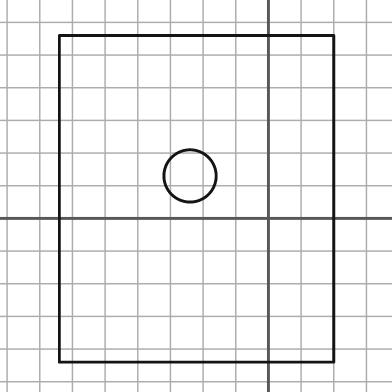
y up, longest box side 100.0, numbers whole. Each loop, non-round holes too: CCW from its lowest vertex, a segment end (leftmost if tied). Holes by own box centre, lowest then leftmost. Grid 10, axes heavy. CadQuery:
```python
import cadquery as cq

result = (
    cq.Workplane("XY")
    .moveTo(-64.0, -44.0)
    .lineTo(20.0, -44.0)
    .lineTo(20.0, 56.0)
    .lineTo(-64.0, 56.0)
    .close()
    .moveTo(-24.0, 13.0)
    .circle(8.0)
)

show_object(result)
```